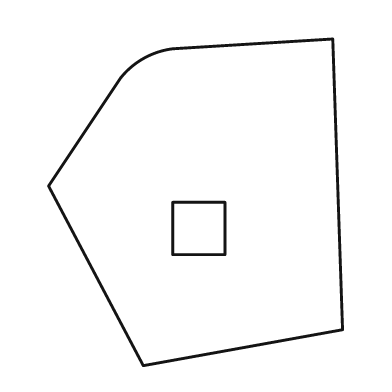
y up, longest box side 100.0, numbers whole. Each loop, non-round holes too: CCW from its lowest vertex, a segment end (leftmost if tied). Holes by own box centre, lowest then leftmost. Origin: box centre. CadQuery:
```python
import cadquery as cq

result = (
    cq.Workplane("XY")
    .moveTo(-16.0, -50.0)
    .lineTo(45.0, -39.0)
    .lineTo(42.0, 50.0)
    .lineTo(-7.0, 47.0)
    .threePointArc((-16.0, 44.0), (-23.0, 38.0))
    .lineTo(-45.0, 5.0)
    .close()
    .moveTo(-7.0, -16.0)
    .lineTo(9.0, -16.0)
    .lineTo(9.0, 0.0)
    .lineTo(-7.0, 0.0)
    .close()
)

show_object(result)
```